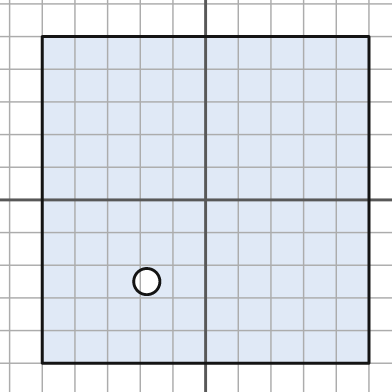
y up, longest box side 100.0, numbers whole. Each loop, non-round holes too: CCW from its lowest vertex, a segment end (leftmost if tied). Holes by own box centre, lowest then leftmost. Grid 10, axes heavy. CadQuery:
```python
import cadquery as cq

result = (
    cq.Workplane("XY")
    .moveTo(-50.0, -50.0)
    .lineTo(50.0, -50.0)
    .lineTo(50.0, 50.0)
    .lineTo(-50.0, 50.0)
    .close()
    .moveTo(-18.0, -25.0)
    .circle(4.0)
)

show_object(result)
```